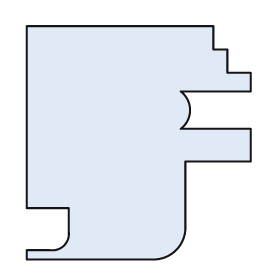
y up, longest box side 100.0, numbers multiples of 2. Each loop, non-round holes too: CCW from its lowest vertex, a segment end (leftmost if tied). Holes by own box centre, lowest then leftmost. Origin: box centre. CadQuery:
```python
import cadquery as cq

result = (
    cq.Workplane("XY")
    .moveTo(-48.0, -50.0)
    .lineTo(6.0, -50.0)
    .threePointArc((16.0, -46.0), (20.0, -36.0))
    .lineTo(20.0, -8.0)
    .lineTo(48.0, -8.0)
    .lineTo(48.0, 6.0)
    .lineTo(18.0, 6.0)
    .threePointArc((22.0, 14.0), (18.0, 22.0))
    .lineTo(48.0, 22.0)
    .lineTo(48.0, 30.0)
    .lineTo(38.0, 30.0)
    .lineTo(38.0, 40.0)
    .lineTo(32.0, 40.0)
    .lineTo(32.0, 50.0)
    .lineTo(-48.0, 50.0)
    .lineTo(-48.0, -28.0)
    .lineTo(-30.0, -28.0)
    .lineTo(-30.0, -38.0)
    .threePointArc((-32.0, -44.0), (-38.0, -46.0))
    .lineTo(-48.0, -46.0)
    .close()
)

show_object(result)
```